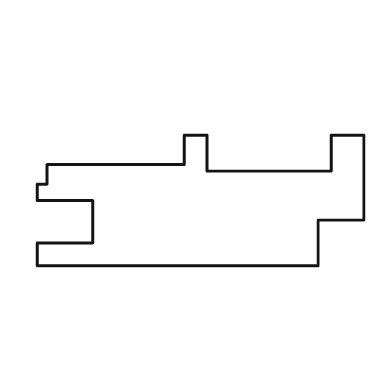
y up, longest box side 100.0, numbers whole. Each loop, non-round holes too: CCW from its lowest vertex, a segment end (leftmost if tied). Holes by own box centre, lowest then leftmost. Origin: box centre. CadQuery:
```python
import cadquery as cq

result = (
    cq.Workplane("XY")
    .moveTo(-50.0, -20.0)
    .lineTo(36.0, -20.0)
    .lineTo(36.0, -6.0)
    .lineTo(50.0, -6.0)
    .lineTo(50.0, 20.0)
    .lineTo(40.0, 20.0)
    .lineTo(40.0, 9.0)
    .lineTo(2.0, 9.0)
    .lineTo(2.0, 20.0)
    .lineTo(-5.0, 20.0)
    .lineTo(-5.0, 11.0)
    .lineTo(-47.0, 11.0)
    .lineTo(-47.0, 5.0)
    .lineTo(-50.0, 5.0)
    .lineTo(-50.0, 0.0)
    .lineTo(-33.0, 0.0)
    .lineTo(-33.0, -13.0)
    .lineTo(-50.0, -13.0)
    .close()
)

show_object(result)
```